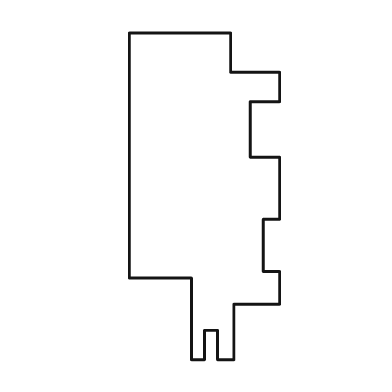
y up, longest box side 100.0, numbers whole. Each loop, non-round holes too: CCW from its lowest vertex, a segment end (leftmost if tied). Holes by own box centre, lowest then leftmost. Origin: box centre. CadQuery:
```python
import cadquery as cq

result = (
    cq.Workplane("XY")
    .moveTo(-4.0, -50.0)
    .lineTo(0.0, -50.0)
    .lineTo(0.0, -41.0)
    .lineTo(4.0, -41.0)
    .lineTo(4.0, -50.0)
    .lineTo(9.0, -50.0)
    .lineTo(9.0, -33.0)
    .lineTo(23.0, -33.0)
    .lineTo(23.0, -23.0)
    .lineTo(18.0, -23.0)
    .lineTo(18.0, -7.0)
    .lineTo(23.0, -7.0)
    .lineTo(23.0, 12.0)
    .lineTo(14.0, 12.0)
    .lineTo(14.0, 29.0)
    .lineTo(23.0, 29.0)
    .lineTo(23.0, 38.0)
    .lineTo(8.0, 38.0)
    .lineTo(8.0, 50.0)
    .lineTo(-23.0, 50.0)
    .lineTo(-23.0, -25.0)
    .lineTo(-4.0, -25.0)
    .close()
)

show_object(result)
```